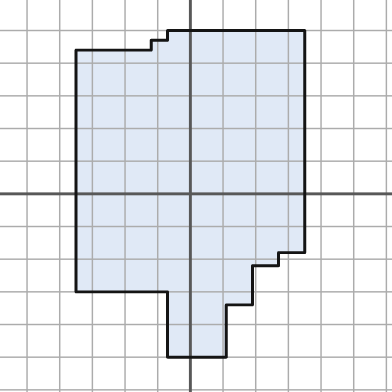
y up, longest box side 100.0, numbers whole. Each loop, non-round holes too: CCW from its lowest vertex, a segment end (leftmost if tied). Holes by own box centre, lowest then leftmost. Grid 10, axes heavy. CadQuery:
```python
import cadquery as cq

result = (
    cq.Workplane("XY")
    .moveTo(-7.0, -50.0)
    .lineTo(11.0, -50.0)
    .lineTo(11.0, -34.0)
    .lineTo(19.0, -34.0)
    .lineTo(19.0, -22.0)
    .lineTo(27.0, -22.0)
    .lineTo(27.0, -18.0)
    .lineTo(35.0, -18.0)
    .lineTo(35.0, 50.0)
    .lineTo(-7.0, 50.0)
    .lineTo(-7.0, 47.0)
    .lineTo(-12.0, 47.0)
    .lineTo(-12.0, 44.0)
    .lineTo(-35.0, 44.0)
    .lineTo(-35.0, -30.0)
    .lineTo(-7.0, -30.0)
    .close()
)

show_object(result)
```